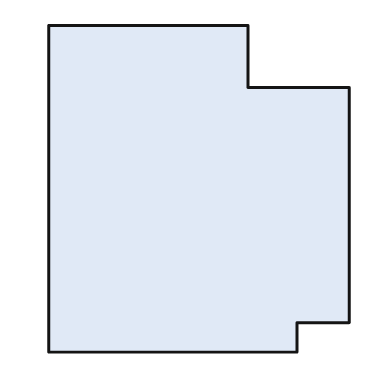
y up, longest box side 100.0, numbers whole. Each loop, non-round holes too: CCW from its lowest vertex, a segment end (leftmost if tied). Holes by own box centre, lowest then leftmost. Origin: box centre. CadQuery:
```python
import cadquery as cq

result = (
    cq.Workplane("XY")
    .moveTo(-46.0, -50.0)
    .lineTo(30.0, -50.0)
    .lineTo(30.0, -41.0)
    .lineTo(46.0, -41.0)
    .lineTo(46.0, 31.0)
    .lineTo(15.0, 31.0)
    .lineTo(15.0, 50.0)
    .lineTo(-46.0, 50.0)
    .close()
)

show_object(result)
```